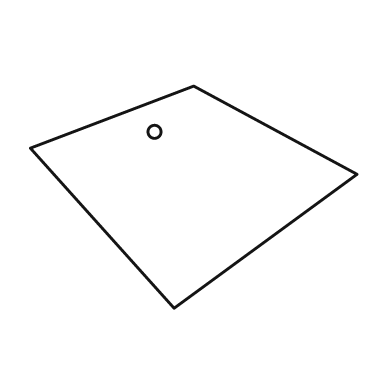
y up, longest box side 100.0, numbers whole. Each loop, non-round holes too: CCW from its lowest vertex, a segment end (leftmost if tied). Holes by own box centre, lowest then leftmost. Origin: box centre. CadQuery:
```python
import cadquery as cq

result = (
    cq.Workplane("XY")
    .moveTo(-6.0, -34.0)
    .lineTo(50.0, 7.0)
    .lineTo(0.0, 34.0)
    .lineTo(-50.0, 15.0)
    .close()
    .moveTo(-12.0, 20.0)
    .circle(2.0)
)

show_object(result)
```